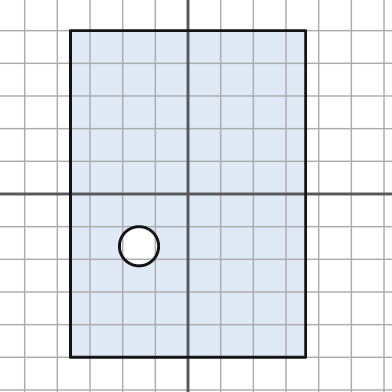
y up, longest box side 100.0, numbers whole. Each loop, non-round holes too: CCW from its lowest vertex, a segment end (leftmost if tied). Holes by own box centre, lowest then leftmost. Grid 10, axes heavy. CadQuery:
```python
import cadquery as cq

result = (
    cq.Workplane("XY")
    .moveTo(-36.0, -50.0)
    .lineTo(36.0, -50.0)
    .lineTo(36.0, 50.0)
    .lineTo(-36.0, 50.0)
    .close()
    .moveTo(-15.0, -16.0)
    .circle(6.0)
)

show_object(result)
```